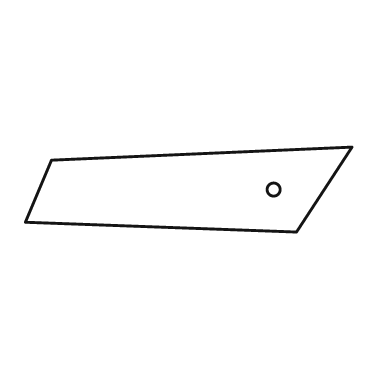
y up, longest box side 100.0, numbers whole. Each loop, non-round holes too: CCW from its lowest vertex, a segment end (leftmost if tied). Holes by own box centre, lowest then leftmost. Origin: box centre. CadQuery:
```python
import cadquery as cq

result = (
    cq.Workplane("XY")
    .moveTo(33.0, -13.0)
    .lineTo(50.0, 13.0)
    .lineTo(-42.0, 9.0)
    .lineTo(-50.0, -10.0)
    .close()
    .moveTo(26.0, 0.0)
    .circle(2.0)
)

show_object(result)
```